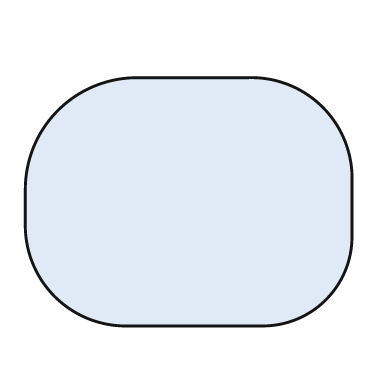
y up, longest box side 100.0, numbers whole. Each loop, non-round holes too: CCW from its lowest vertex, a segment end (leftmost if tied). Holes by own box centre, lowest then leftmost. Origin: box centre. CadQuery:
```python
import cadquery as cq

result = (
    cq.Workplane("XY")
    .moveTo(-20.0, -38.0)
    .lineTo(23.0, -38.0)
    .threePointArc((42.0, -30.0), (50.0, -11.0))
    .lineTo(50.0, 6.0)
    .threePointArc((41.0, 29.0), (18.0, 38.0))
    .lineTo(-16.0, 38.0)
    .threePointArc((-40.0, 28.0), (-50.0, 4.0))
    .lineTo(-50.0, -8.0)
    .threePointArc((-41.0, -29.0), (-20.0, -38.0))
    .close()
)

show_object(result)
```